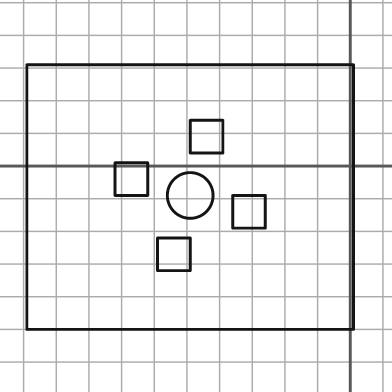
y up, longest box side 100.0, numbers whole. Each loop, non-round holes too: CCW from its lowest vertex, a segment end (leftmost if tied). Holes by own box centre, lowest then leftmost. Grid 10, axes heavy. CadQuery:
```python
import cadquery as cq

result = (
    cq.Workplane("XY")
    .moveTo(-99.0, -50.0)
    .lineTo(1.0, -50.0)
    .lineTo(1.0, 31.0)
    .lineTo(-99.0, 31.0)
    .close()
    .moveTo(-59.0, -32.0)
    .lineTo(-49.0, -32.0)
    .lineTo(-49.0, -22.0)
    .lineTo(-59.0, -22.0)
    .close()
    .moveTo(-36.0, -19.0)
    .lineTo(-26.0, -19.0)
    .lineTo(-26.0, -9.0)
    .lineTo(-36.0, -9.0)
    .close()
    .moveTo(-49.0, -9.0)
    .circle(7.0)
    .moveTo(-72.0, -9.0)
    .lineTo(-62.0, -9.0)
    .lineTo(-62.0, 1.0)
    .lineTo(-72.0, 1.0)
    .close()
    .moveTo(-49.0, 4.0)
    .lineTo(-39.0, 4.0)
    .lineTo(-39.0, 14.0)
    .lineTo(-49.0, 14.0)
    .close()
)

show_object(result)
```